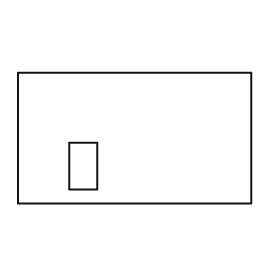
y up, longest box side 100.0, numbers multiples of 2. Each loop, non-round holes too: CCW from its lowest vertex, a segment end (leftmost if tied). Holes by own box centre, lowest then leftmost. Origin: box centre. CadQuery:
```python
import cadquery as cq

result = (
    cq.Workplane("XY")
    .moveTo(-50.0, -28.0)
    .lineTo(50.0, -28.0)
    .lineTo(50.0, 28.0)
    .lineTo(-50.0, 28.0)
    .close()
    .moveTo(-28.0, -22.0)
    .lineTo(-16.0, -22.0)
    .lineTo(-16.0, -2.0)
    .lineTo(-28.0, -2.0)
    .close()
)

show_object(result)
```